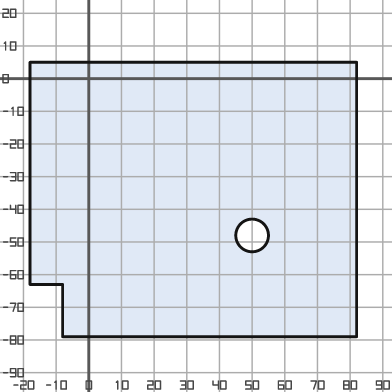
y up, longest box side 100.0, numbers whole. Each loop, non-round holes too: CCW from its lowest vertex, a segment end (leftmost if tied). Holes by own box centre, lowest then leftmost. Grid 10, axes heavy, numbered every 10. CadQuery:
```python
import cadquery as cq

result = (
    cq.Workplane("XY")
    .moveTo(-8.0, -79.0)
    .lineTo(82.0, -79.0)
    .lineTo(82.0, 5.0)
    .lineTo(-18.0, 5.0)
    .lineTo(-18.0, -63.0)
    .lineTo(-8.0, -63.0)
    .close()
    .moveTo(50.0, -48.0)
    .circle(5.0)
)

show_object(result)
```